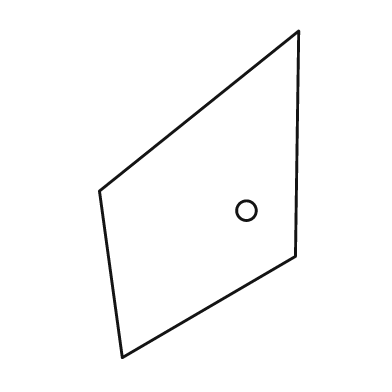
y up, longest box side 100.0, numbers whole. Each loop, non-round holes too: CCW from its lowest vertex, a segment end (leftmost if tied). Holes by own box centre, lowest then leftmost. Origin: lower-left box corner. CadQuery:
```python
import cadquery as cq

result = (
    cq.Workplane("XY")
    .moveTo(7.0, 0.0)
    .lineTo(60.0, 31.0)
    .lineTo(61.0, 100.0)
    .lineTo(0.0, 51.0)
    .close()
    .moveTo(45.0, 45.0)
    .circle(3.0)
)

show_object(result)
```